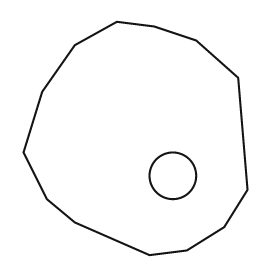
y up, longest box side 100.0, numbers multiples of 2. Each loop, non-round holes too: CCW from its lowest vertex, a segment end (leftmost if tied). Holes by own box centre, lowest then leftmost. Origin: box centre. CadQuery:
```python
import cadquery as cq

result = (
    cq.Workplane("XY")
    .moveTo(6.0, -50.0)
    .lineTo(22.0, -48.0)
    .lineTo(38.0, -38.0)
    .lineTo(48.0, -22.0)
    .lineTo(44.0, 26.0)
    .lineTo(26.0, 42.0)
    .lineTo(8.0, 48.0)
    .lineTo(-8.0, 50.0)
    .lineTo(-26.0, 40.0)
    .lineTo(-40.0, 20.0)
    .lineTo(-48.0, -6.0)
    .lineTo(-38.0, -26.0)
    .lineTo(-26.0, -36.0)
    .close()
    .moveTo(16.0, -16.0)
    .circle(10.0)
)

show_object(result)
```